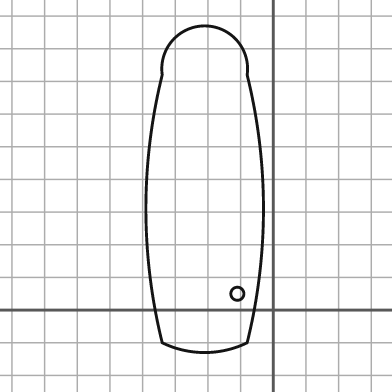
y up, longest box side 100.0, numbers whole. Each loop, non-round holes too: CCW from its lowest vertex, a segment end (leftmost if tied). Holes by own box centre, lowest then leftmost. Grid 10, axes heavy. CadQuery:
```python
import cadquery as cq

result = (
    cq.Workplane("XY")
    .moveTo(-34.0, -10.0)
    .threePointArc((-21.0, -13.0), (-8.0, -10.0))
    .threePointArc((-3.0, 31.0), (-8.0, 72.0))
    .threePointArc((-21.0, 87.0), (-34.0, 72.0))
    .threePointArc((-39.0, 31.0), (-34.0, -10.0))
    .close()
    .moveTo(-11.0, 5.0)
    .circle(2.0)
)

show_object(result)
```